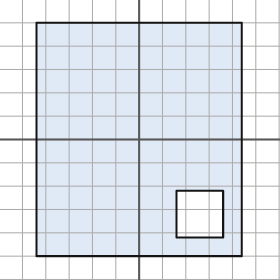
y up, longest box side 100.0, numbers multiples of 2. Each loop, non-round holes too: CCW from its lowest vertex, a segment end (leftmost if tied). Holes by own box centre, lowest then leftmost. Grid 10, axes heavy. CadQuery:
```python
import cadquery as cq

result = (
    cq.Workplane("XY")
    .moveTo(-44.0, -50.0)
    .lineTo(44.0, -50.0)
    .lineTo(44.0, 50.0)
    .lineTo(-44.0, 50.0)
    .close()
    .moveTo(16.0, -42.0)
    .lineTo(36.0, -42.0)
    .lineTo(36.0, -22.0)
    .lineTo(16.0, -22.0)
    .close()
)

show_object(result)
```